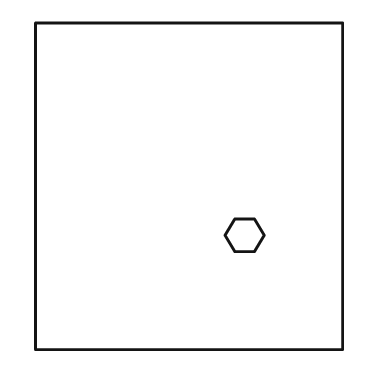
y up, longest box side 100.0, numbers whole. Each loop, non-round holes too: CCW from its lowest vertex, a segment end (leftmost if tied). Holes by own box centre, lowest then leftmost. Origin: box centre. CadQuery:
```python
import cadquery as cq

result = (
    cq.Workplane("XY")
    .moveTo(-47.0, -50.0)
    .lineTo(47.0, -50.0)
    .lineTo(47.0, 50.0)
    .lineTo(-47.0, 50.0)
    .close()
    .moveTo(14.0, -20.0)
    .lineTo(20.0, -20.0)
    .lineTo(23.0, -15.0)
    .lineTo(20.0, -10.0)
    .lineTo(14.0, -10.0)
    .lineTo(11.0, -15.0)
    .close()
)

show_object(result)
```